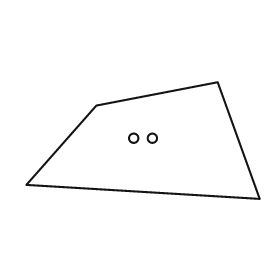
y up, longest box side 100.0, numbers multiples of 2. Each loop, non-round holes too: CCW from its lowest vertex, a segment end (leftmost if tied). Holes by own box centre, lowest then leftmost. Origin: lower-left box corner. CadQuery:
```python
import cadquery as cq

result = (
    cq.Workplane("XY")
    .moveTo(100.0, 0.0)
    .lineTo(82.0, 50.0)
    .lineTo(30.0, 40.0)
    .lineTo(0.0, 6.0)
    .close()
    .moveTo(46.0, 26.0)
    .circle(2.0)
    .moveTo(54.0, 26.0)
    .circle(2.0)
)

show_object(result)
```